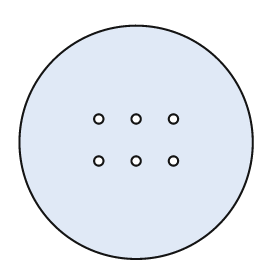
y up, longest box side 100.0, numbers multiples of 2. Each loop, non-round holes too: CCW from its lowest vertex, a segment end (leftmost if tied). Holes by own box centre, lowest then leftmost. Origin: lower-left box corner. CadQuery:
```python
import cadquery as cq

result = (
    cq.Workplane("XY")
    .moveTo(50.0, 50.0)
    .circle(50.0)
    .moveTo(34.0, 42.0)
    .circle(2.0)
    .moveTo(50.0, 42.0)
    .circle(2.0)
    .moveTo(66.0, 42.0)
    .circle(2.0)
    .moveTo(34.0, 60.0)
    .circle(2.0)
    .moveTo(50.0, 60.0)
    .circle(2.0)
    .moveTo(66.0, 60.0)
    .circle(2.0)
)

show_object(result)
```